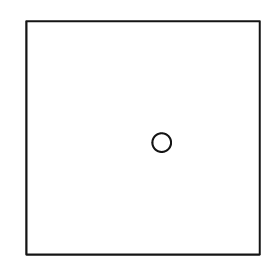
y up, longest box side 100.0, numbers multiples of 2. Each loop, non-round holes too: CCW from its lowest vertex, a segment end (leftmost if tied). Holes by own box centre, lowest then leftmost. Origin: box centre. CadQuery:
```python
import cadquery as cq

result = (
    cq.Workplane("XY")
    .moveTo(-50.0, -50.0)
    .lineTo(50.0, -50.0)
    .lineTo(50.0, 50.0)
    .lineTo(-50.0, 50.0)
    .close()
    .moveTo(8.0, -2.0)
    .circle(4.0)
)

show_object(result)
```